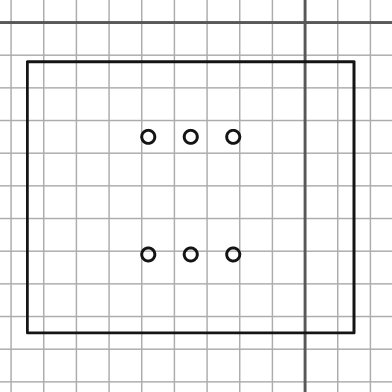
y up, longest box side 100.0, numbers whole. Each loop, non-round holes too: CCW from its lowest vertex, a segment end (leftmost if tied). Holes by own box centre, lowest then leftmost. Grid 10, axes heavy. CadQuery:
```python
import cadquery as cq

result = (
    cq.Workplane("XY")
    .moveTo(-85.0, -95.0)
    .lineTo(15.0, -95.0)
    .lineTo(15.0, -12.0)
    .lineTo(-85.0, -12.0)
    .close()
    .moveTo(-48.0, -71.0)
    .circle(2.0)
    .moveTo(-35.0, -71.0)
    .circle(2.0)
    .moveTo(-22.0, -71.0)
    .circle(2.0)
    .moveTo(-48.0, -35.0)
    .circle(2.0)
    .moveTo(-35.0, -35.0)
    .circle(2.0)
    .moveTo(-22.0, -35.0)
    .circle(2.0)
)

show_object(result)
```